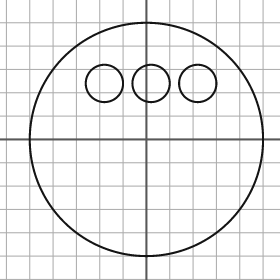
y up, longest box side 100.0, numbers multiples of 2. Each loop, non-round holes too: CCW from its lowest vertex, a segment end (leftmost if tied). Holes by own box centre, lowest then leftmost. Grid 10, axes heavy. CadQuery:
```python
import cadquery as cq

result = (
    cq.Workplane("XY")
    .moveTo(0.0, 0.0)
    .circle(50.0)
    .moveTo(-18.0, 24.0)
    .circle(8.0)
    .moveTo(2.0, 24.0)
    .circle(8.0)
    .moveTo(22.0, 24.0)
    .circle(8.0)
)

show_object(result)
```